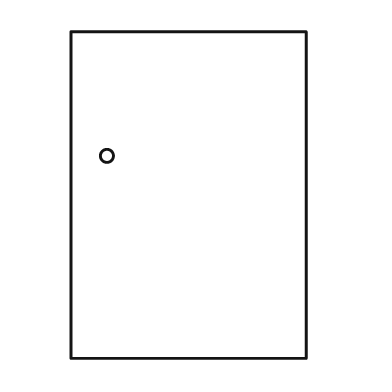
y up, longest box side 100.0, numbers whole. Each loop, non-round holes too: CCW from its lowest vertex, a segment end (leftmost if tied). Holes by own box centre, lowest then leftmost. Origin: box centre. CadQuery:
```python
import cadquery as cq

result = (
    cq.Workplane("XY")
    .moveTo(-36.0, -50.0)
    .lineTo(36.0, -50.0)
    .lineTo(36.0, 50.0)
    .lineTo(-36.0, 50.0)
    .close()
    .moveTo(-25.0, 12.0)
    .circle(2.0)
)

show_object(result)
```